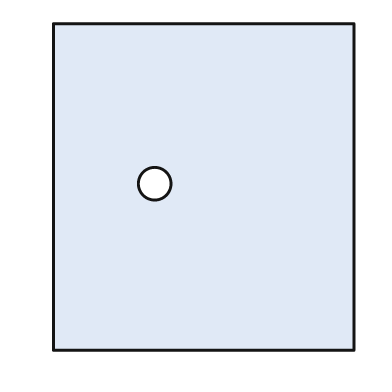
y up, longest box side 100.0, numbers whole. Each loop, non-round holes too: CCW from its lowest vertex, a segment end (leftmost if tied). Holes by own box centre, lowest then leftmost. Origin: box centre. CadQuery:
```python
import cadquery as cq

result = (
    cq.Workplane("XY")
    .moveTo(-46.0, -50.0)
    .lineTo(46.0, -50.0)
    .lineTo(46.0, 50.0)
    .lineTo(-46.0, 50.0)
    .close()
    .moveTo(-15.0, 1.0)
    .circle(5.0)
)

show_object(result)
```